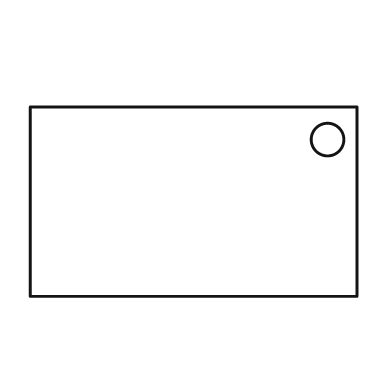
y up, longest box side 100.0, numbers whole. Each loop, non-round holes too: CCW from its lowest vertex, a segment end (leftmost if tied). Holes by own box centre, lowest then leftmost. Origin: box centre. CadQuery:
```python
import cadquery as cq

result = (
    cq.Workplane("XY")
    .moveTo(-50.0, -29.0)
    .lineTo(50.0, -29.0)
    .lineTo(50.0, 29.0)
    .lineTo(-50.0, 29.0)
    .close()
    .moveTo(41.0, 19.0)
    .circle(5.0)
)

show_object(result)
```